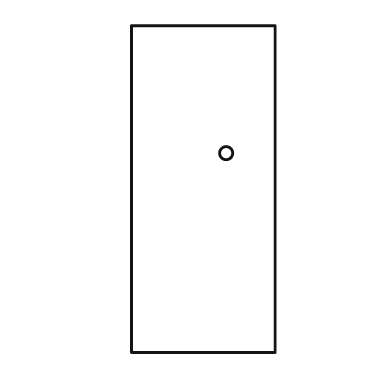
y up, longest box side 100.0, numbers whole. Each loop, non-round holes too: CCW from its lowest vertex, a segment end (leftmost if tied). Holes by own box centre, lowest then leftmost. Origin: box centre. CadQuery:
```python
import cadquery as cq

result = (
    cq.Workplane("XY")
    .moveTo(-22.0, -50.0)
    .lineTo(22.0, -50.0)
    .lineTo(22.0, 50.0)
    .lineTo(-22.0, 50.0)
    .close()
    .moveTo(7.0, 11.0)
    .circle(2.0)
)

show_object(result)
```